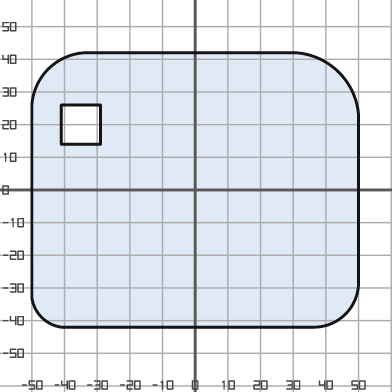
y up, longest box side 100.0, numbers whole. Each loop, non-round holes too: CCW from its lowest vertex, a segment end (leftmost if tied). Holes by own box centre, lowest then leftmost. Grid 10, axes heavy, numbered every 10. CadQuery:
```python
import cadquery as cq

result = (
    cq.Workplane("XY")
    .moveTo(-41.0, -42.0)
    .lineTo(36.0, -42.0)
    .threePointArc((46.0, -38.0), (50.0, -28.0))
    .lineTo(50.0, 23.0)
    .threePointArc((44.0, 36.0), (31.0, 42.0))
    .lineTo(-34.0, 42.0)
    .threePointArc((-45.0, 37.0), (-50.0, 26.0))
    .lineTo(-50.0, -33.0)
    .threePointArc((-47.0, -39.0), (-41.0, -42.0))
    .close()
    .moveTo(-41.0, 14.0)
    .lineTo(-29.0, 14.0)
    .lineTo(-29.0, 26.0)
    .lineTo(-41.0, 26.0)
    .close()
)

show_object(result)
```